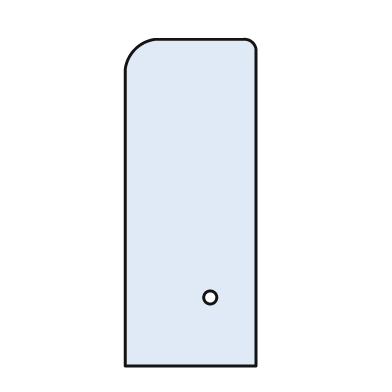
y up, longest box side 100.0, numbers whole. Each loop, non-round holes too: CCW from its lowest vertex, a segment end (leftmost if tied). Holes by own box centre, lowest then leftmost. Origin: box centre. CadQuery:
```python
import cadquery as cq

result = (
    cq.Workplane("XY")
    .moveTo(-20.0, -50.0)
    .lineTo(20.0, -50.0)
    .lineTo(20.0, 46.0)
    .threePointArc((19.0, 49.0), (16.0, 50.0))
    .lineTo(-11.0, 50.0)
    .threePointArc((-17.0, 47.0), (-20.0, 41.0))
    .close()
    .moveTo(6.0, -29.0)
    .circle(2.0)
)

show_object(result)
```